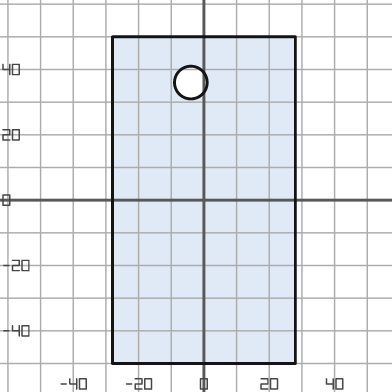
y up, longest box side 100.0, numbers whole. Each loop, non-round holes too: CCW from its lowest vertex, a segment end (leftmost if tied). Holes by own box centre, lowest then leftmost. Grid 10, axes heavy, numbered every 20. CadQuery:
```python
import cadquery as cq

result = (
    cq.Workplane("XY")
    .moveTo(-28.0, -50.0)
    .lineTo(28.0, -50.0)
    .lineTo(28.0, 50.0)
    .lineTo(-28.0, 50.0)
    .close()
    .moveTo(-4.0, 36.0)
    .circle(5.0)
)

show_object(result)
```